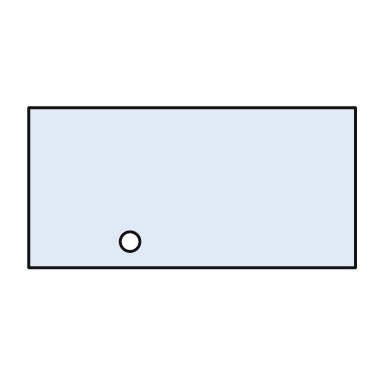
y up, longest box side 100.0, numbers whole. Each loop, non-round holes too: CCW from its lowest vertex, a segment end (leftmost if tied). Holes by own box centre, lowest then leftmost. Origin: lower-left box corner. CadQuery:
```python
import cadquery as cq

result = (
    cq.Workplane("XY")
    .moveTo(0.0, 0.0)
    .lineTo(100.0, 0.0)
    .lineTo(100.0, 49.0)
    .lineTo(0.0, 49.0)
    .close()
    .moveTo(31.0, 8.0)
    .circle(3.0)
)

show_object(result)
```